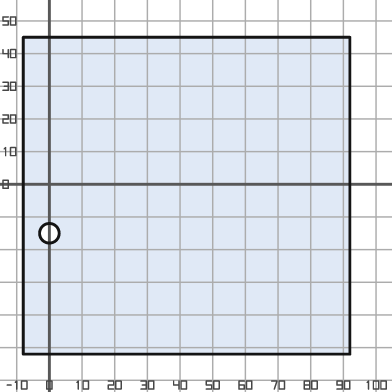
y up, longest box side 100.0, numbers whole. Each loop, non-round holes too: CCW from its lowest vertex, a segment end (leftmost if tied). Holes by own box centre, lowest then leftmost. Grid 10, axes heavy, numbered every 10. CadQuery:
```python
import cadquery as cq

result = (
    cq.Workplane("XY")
    .moveTo(-8.0, -52.0)
    .lineTo(92.0, -52.0)
    .lineTo(92.0, 45.0)
    .lineTo(-8.0, 45.0)
    .close()
    .moveTo(0.0, -15.0)
    .circle(3.0)
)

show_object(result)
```